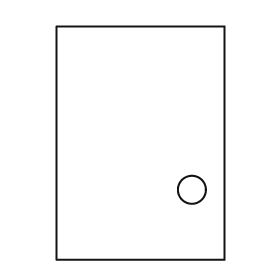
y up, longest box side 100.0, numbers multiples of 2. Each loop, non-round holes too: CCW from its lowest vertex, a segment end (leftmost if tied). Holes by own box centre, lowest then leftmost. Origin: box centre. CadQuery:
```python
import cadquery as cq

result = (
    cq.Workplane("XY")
    .moveTo(-36.0, -50.0)
    .lineTo(36.0, -50.0)
    .lineTo(36.0, 50.0)
    .lineTo(-36.0, 50.0)
    .close()
    .moveTo(22.0, -20.0)
    .circle(6.0)
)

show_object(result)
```